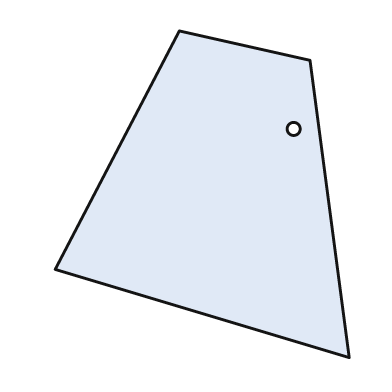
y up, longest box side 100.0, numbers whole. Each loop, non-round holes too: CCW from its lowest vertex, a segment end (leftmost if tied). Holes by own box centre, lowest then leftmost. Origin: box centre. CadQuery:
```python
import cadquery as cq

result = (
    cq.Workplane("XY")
    .moveTo(45.0, -50.0)
    .lineTo(33.0, 41.0)
    .lineTo(-7.0, 50.0)
    .lineTo(-45.0, -23.0)
    .close()
    .moveTo(28.0, 20.0)
    .circle(2.0)
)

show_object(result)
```